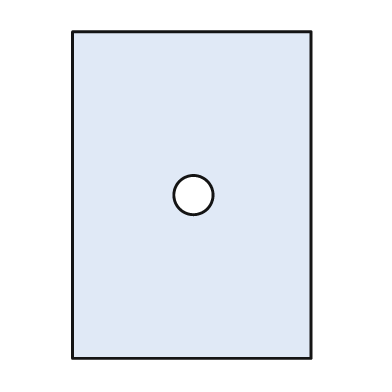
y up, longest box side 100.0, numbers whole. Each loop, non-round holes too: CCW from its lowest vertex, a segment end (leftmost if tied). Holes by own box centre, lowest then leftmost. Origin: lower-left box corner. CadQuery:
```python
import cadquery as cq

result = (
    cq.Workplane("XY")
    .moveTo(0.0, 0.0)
    .lineTo(73.0, 0.0)
    .lineTo(73.0, 100.0)
    .lineTo(0.0, 100.0)
    .close()
    .moveTo(37.0, 50.0)
    .circle(6.0)
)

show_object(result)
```